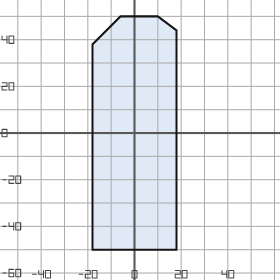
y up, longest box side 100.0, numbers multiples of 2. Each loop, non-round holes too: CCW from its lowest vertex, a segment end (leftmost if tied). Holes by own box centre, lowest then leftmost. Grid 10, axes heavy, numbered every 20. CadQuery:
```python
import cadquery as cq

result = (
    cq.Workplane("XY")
    .moveTo(-18.0, -50.0)
    .lineTo(18.0, -50.0)
    .lineTo(18.0, 44.0)
    .lineTo(10.0, 50.0)
    .lineTo(-6.0, 50.0)
    .lineTo(-18.0, 38.0)
    .close()
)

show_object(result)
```